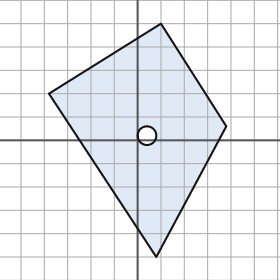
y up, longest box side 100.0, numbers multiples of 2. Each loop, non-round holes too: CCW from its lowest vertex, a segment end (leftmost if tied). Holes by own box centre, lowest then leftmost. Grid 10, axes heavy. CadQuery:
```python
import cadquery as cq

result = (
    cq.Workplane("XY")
    .moveTo(8.0, -50.0)
    .lineTo(38.0, 6.0)
    .lineTo(10.0, 50.0)
    .lineTo(-38.0, 20.0)
    .close()
    .moveTo(4.0, 2.0)
    .circle(4.0)
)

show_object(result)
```